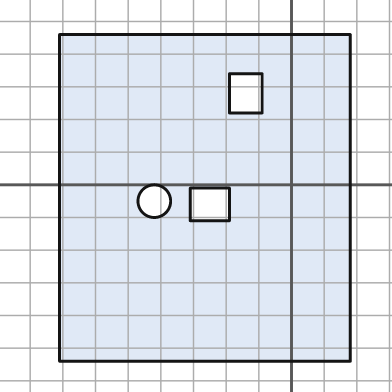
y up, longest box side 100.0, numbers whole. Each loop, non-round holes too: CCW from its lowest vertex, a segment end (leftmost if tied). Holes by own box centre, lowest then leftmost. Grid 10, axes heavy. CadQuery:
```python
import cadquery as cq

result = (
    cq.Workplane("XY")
    .moveTo(-71.0, -54.0)
    .lineTo(18.0, -54.0)
    .lineTo(18.0, 46.0)
    .lineTo(-71.0, 46.0)
    .close()
    .moveTo(-31.0, -11.0)
    .lineTo(-19.0, -11.0)
    .lineTo(-19.0, -1.0)
    .lineTo(-31.0, -1.0)
    .close()
    .moveTo(-42.0, -5.0)
    .circle(5.0)
    .moveTo(-19.0, 22.0)
    .lineTo(-9.0, 22.0)
    .lineTo(-9.0, 34.0)
    .lineTo(-19.0, 34.0)
    .close()
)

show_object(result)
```